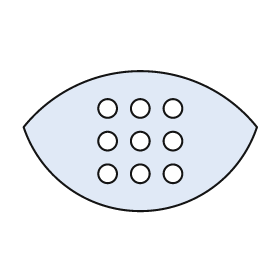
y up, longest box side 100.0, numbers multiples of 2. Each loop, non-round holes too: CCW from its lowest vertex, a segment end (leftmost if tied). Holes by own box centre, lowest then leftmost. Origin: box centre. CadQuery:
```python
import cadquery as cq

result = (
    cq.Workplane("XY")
    .moveTo(-50.0, 6.0)
    .threePointArc((0.0, -30.0), (50.0, 6.0))
    .threePointArc((0.0, 30.0), (-50.0, 6.0))
    .close()
    .moveTo(-14.0, -14.0)
    .circle(4.0)
    .moveTo(0.0, -14.0)
    .circle(4.0)
    .moveTo(14.0, -14.0)
    .circle(4.0)
    .moveTo(-14.0, 0.0)
    .circle(4.0)
    .moveTo(0.0, 0.0)
    .circle(4.0)
    .moveTo(14.0, 0.0)
    .circle(4.0)
    .moveTo(-14.0, 14.0)
    .circle(4.0)
    .moveTo(0.0, 14.0)
    .circle(4.0)
    .moveTo(14.0, 14.0)
    .circle(4.0)
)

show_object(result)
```